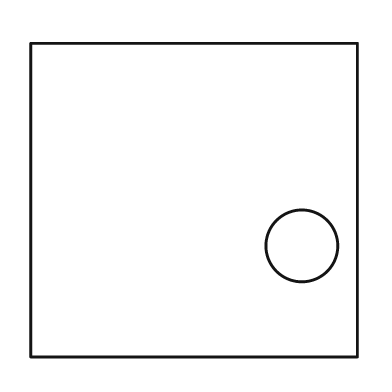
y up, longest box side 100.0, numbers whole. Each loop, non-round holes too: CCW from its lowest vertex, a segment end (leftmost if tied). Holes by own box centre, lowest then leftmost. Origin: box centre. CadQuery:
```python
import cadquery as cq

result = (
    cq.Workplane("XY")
    .moveTo(-50.0, -48.0)
    .lineTo(50.0, -48.0)
    .lineTo(50.0, 48.0)
    .lineTo(-50.0, 48.0)
    .close()
    .moveTo(33.0, -14.0)
    .circle(11.0)
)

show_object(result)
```